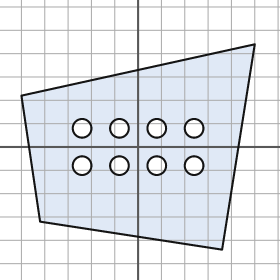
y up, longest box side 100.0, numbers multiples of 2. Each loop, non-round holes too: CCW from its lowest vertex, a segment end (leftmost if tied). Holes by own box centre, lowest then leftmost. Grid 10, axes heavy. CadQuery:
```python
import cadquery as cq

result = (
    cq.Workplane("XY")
    .moveTo(36.0, -44.0)
    .lineTo(50.0, 44.0)
    .lineTo(-50.0, 22.0)
    .lineTo(-42.0, -32.0)
    .close()
    .moveTo(-24.0, -8.0)
    .circle(4.0)
    .moveTo(-8.0, -8.0)
    .circle(4.0)
    .moveTo(8.0, -8.0)
    .circle(4.0)
    .moveTo(24.0, -8.0)
    .circle(4.0)
    .moveTo(-24.0, 8.0)
    .circle(4.0)
    .moveTo(-8.0, 8.0)
    .circle(4.0)
    .moveTo(8.0, 8.0)
    .circle(4.0)
    .moveTo(24.0, 8.0)
    .circle(4.0)
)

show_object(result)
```